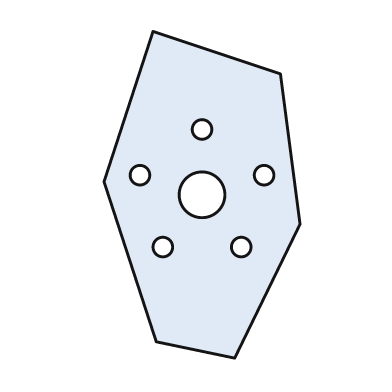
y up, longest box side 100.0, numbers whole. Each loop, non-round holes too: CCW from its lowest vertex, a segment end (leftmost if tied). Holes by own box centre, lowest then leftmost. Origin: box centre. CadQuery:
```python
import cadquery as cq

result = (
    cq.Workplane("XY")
    .moveTo(10.0, -50.0)
    .lineTo(30.0, -9.0)
    .lineTo(24.0, 37.0)
    .lineTo(-15.0, 50.0)
    .lineTo(-30.0, 4.0)
    .lineTo(-14.0, -45.0)
    .close()
    .moveTo(-12.0, -16.0)
    .circle(3.0)
    .moveTo(12.0, -16.0)
    .circle(3.0)
    .moveTo(0.0, 0.0)
    .circle(7.0)
    .moveTo(-19.0, 6.0)
    .circle(3.0)
    .moveTo(19.0, 6.0)
    .circle(3.0)
    .moveTo(0.0, 20.0)
    .circle(3.0)
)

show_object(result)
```